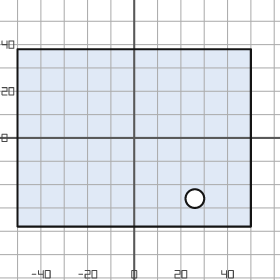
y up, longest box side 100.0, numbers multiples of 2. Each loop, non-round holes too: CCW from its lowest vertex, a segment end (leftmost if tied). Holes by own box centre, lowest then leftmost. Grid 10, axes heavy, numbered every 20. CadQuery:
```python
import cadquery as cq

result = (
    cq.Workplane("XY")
    .moveTo(-50.0, -38.0)
    .lineTo(50.0, -38.0)
    .lineTo(50.0, 38.0)
    .lineTo(-50.0, 38.0)
    .close()
    .moveTo(26.0, -26.0)
    .circle(4.0)
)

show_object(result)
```